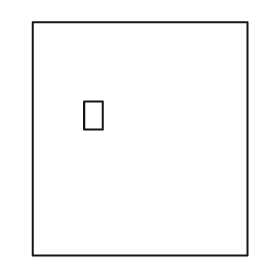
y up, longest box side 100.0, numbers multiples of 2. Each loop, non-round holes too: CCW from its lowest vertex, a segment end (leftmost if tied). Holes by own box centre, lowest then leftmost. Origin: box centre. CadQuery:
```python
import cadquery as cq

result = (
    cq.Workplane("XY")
    .moveTo(-46.0, -50.0)
    .lineTo(46.0, -50.0)
    .lineTo(46.0, 50.0)
    .lineTo(-46.0, 50.0)
    .close()
    .moveTo(-24.0, 4.0)
    .lineTo(-16.0, 4.0)
    .lineTo(-16.0, 16.0)
    .lineTo(-24.0, 16.0)
    .close()
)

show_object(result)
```